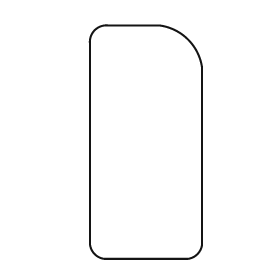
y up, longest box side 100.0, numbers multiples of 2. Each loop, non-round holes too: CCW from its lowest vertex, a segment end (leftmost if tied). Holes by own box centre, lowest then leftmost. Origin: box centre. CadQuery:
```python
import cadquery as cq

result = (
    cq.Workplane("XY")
    .moveTo(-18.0, -50.0)
    .lineTo(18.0, -50.0)
    .threePointArc((22.0, -48.0), (24.0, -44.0))
    .lineTo(24.0, 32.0)
    .threePointArc((18.0, 44.0), (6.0, 50.0))
    .lineTo(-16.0, 50.0)
    .threePointArc((-22.0, 48.0), (-24.0, 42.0))
    .lineTo(-24.0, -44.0)
    .threePointArc((-22.0, -48.0), (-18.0, -50.0))
    .close()
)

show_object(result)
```